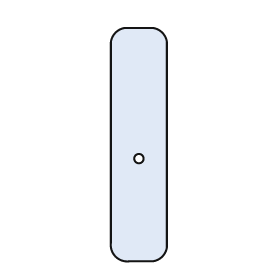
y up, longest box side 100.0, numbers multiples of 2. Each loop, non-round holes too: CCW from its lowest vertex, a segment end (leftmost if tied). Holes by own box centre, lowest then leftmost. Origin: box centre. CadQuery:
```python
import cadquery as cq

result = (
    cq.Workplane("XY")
    .moveTo(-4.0, -50.0)
    .lineTo(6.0, -50.0)
    .threePointArc((10.0, -48.0), (12.0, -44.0))
    .lineTo(12.0, 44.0)
    .threePointArc((10.0, 48.0), (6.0, 50.0))
    .lineTo(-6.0, 50.0)
    .threePointArc((-10.0, 48.0), (-12.0, 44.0))
    .lineTo(-12.0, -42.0)
    .threePointArc((-10.0, -48.0), (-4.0, -50.0))
    .close()
    .moveTo(0.0, -6.0)
    .circle(2.0)
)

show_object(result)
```